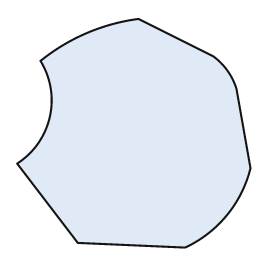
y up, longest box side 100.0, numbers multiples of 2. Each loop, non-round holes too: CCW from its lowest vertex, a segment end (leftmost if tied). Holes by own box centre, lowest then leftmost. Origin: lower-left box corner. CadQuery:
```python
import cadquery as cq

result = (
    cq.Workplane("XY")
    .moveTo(72.0, 0.0)
    .threePointArc((90.0, 14.0), (100.0, 34.0))
    .lineTo(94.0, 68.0)
    .threePointArc((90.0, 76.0), (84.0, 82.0))
    .lineTo(52.0, 98.0)
    .threePointArc((30.0, 92.0), (10.0, 80.0))
    .threePointArc((14.0, 56.0), (0.0, 36.0))
    .lineTo(26.0, 2.0)
    .close()
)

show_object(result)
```